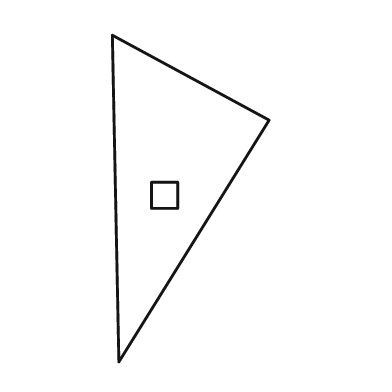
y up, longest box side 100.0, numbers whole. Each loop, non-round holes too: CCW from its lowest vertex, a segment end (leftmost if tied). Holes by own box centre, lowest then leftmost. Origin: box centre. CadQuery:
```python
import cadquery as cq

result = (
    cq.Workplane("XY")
    .moveTo(-22.0, -50.0)
    .lineTo(24.0, 24.0)
    .lineTo(-24.0, 50.0)
    .close()
    .moveTo(-12.0, -3.0)
    .lineTo(-4.0, -3.0)
    .lineTo(-4.0, 5.0)
    .lineTo(-12.0, 5.0)
    .close()
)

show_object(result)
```